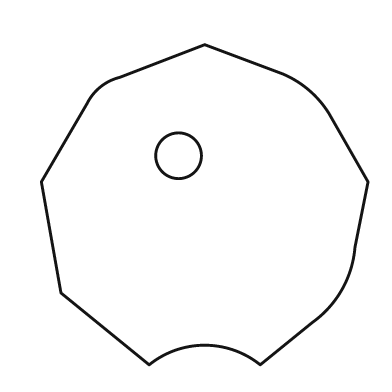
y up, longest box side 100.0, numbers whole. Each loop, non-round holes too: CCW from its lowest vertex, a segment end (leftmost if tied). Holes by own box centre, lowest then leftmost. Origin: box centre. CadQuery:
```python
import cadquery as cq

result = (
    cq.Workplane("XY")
    .moveTo(-17.0, -49.0)
    .threePointArc((0.0, -43.0), (17.0, -49.0))
    .lineTo(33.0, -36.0)
    .threePointArc((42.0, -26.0), (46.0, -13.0))
    .lineTo(50.0, 7.0)
    .lineTo(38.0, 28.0)
    .threePointArc((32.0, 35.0), (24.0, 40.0))
    .lineTo(0.0, 49.0)
    .lineTo(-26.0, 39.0)
    .threePointArc((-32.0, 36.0), (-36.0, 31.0))
    .lineTo(-50.0, 7.0)
    .lineTo(-44.0, -27.0)
    .close()
    .moveTo(-8.0, 15.0)
    .circle(7.0)
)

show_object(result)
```